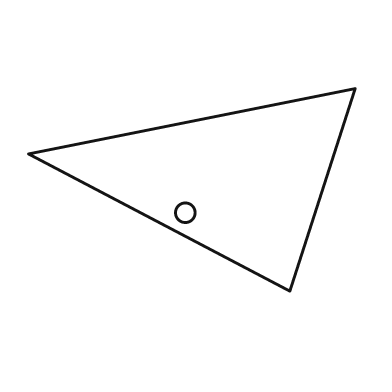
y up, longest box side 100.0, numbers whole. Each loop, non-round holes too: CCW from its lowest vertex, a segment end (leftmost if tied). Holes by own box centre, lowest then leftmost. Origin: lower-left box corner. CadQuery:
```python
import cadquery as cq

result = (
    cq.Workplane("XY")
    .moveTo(80.0, 0.0)
    .lineTo(100.0, 62.0)
    .lineTo(0.0, 42.0)
    .close()
    .moveTo(48.0, 24.0)
    .circle(3.0)
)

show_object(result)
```